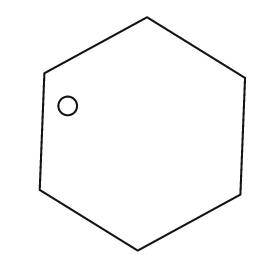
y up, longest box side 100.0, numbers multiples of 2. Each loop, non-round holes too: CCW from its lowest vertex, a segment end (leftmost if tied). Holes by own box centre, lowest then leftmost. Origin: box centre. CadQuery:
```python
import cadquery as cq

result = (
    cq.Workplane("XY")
    .moveTo(-2.0, -50.0)
    .lineTo(42.0, -26.0)
    .lineTo(44.0, 24.0)
    .lineTo(2.0, 50.0)
    .lineTo(-42.0, 26.0)
    .lineTo(-44.0, -24.0)
    .close()
    .moveTo(-32.0, 12.0)
    .circle(4.0)
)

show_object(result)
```